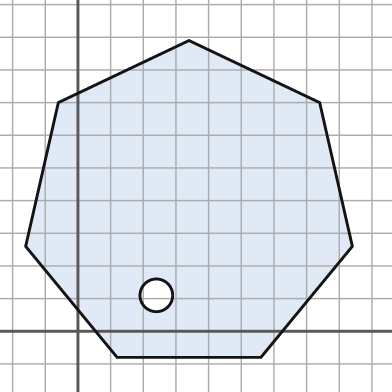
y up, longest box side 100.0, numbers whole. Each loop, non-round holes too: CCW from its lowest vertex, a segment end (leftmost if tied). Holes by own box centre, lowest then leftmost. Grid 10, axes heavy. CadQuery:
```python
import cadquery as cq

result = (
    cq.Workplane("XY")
    .moveTo(12.0, -8.0)
    .lineTo(56.0, -8.0)
    .lineTo(84.0, 26.0)
    .lineTo(74.0, 70.0)
    .lineTo(34.0, 89.0)
    .lineTo(-6.0, 70.0)
    .lineTo(-16.0, 26.0)
    .close()
    .moveTo(24.0, 11.0)
    .circle(5.0)
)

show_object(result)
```